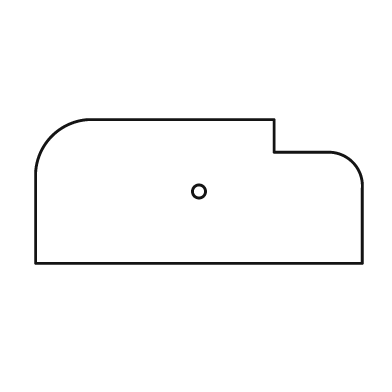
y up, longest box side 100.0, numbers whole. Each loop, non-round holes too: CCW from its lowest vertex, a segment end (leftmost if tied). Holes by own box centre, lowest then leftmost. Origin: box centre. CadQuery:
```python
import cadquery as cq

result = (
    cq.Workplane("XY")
    .moveTo(-50.0, -22.0)
    .lineTo(50.0, -22.0)
    .lineTo(50.0, 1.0)
    .threePointArc((47.0, 9.0), (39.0, 12.0))
    .lineTo(23.0, 12.0)
    .lineTo(23.0, 22.0)
    .lineTo(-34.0, 22.0)
    .threePointArc((-45.0, 17.0), (-50.0, 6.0))
    .close()
    .moveTo(0.0, 0.0)
    .circle(2.0)
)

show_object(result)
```